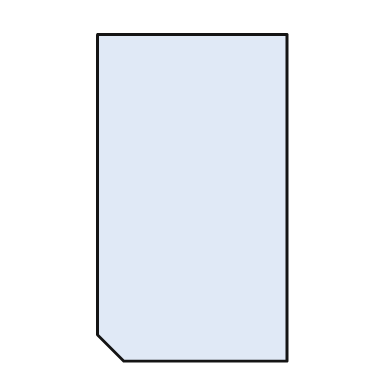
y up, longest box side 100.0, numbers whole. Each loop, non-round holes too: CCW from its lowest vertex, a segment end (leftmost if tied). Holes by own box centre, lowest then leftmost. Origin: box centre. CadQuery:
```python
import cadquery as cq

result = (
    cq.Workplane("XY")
    .moveTo(-21.0, -50.0)
    .lineTo(29.0, -50.0)
    .lineTo(29.0, 50.0)
    .lineTo(-29.0, 50.0)
    .lineTo(-29.0, -42.0)
    .close()
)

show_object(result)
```